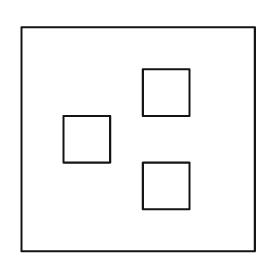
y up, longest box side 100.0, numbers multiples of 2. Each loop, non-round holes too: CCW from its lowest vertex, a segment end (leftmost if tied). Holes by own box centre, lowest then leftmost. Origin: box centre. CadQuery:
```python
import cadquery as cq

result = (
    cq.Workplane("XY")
    .moveTo(-50.0, -48.0)
    .lineTo(50.0, -48.0)
    .lineTo(50.0, 48.0)
    .lineTo(-50.0, 48.0)
    .close()
    .moveTo(2.0, -30.0)
    .lineTo(22.0, -30.0)
    .lineTo(22.0, -10.0)
    .lineTo(2.0, -10.0)
    .close()
    .moveTo(-32.0, -10.0)
    .lineTo(-12.0, -10.0)
    .lineTo(-12.0, 10.0)
    .lineTo(-32.0, 10.0)
    .close()
    .moveTo(2.0, 10.0)
    .lineTo(22.0, 10.0)
    .lineTo(22.0, 30.0)
    .lineTo(2.0, 30.0)
    .close()
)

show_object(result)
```